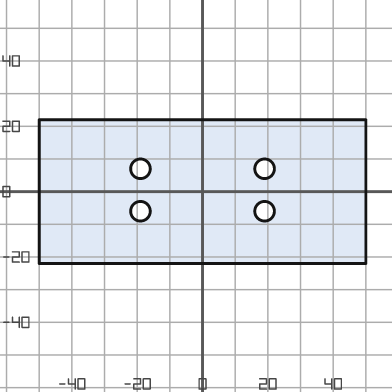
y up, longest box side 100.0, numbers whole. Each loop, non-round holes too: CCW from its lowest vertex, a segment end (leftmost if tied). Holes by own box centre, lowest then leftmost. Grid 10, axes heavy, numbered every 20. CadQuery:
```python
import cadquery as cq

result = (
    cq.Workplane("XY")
    .moveTo(-50.0, -22.0)
    .lineTo(50.0, -22.0)
    .lineTo(50.0, 22.0)
    .lineTo(-50.0, 22.0)
    .close()
    .moveTo(-19.0, -6.0)
    .circle(3.0)
    .moveTo(19.0, -6.0)
    .circle(3.0)
    .moveTo(-19.0, 7.0)
    .circle(3.0)
    .moveTo(19.0, 7.0)
    .circle(3.0)
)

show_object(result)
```